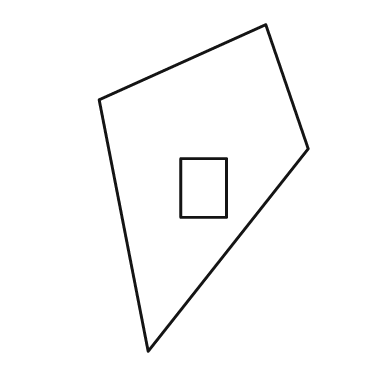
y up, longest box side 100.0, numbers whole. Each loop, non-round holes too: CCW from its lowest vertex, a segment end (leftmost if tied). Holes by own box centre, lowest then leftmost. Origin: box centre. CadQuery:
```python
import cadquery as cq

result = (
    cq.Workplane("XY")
    .moveTo(-17.0, -50.0)
    .lineTo(32.0, 12.0)
    .lineTo(19.0, 50.0)
    .lineTo(-32.0, 27.0)
    .close()
    .moveTo(-7.0, -9.0)
    .lineTo(7.0, -9.0)
    .lineTo(7.0, 9.0)
    .lineTo(-7.0, 9.0)
    .close()
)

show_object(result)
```